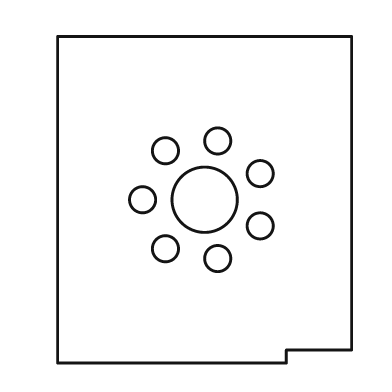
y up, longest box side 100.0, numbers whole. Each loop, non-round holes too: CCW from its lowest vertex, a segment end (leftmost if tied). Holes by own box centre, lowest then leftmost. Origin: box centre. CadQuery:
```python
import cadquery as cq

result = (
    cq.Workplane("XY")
    .moveTo(-45.0, -50.0)
    .lineTo(25.0, -50.0)
    .lineTo(25.0, -46.0)
    .lineTo(45.0, -46.0)
    .lineTo(45.0, 50.0)
    .lineTo(-45.0, 50.0)
    .close()
    .moveTo(4.0, -18.0)
    .circle(4.0)
    .moveTo(-12.0, -15.0)
    .circle(4.0)
    .moveTo(17.0, -8.0)
    .circle(4.0)
    .moveTo(-19.0, 0.0)
    .circle(4.0)
    .moveTo(0.0, 0.0)
    .circle(10.0)
    .moveTo(17.0, 8.0)
    .circle(4.0)
    .moveTo(-12.0, 15.0)
    .circle(4.0)
    .moveTo(4.0, 18.0)
    .circle(4.0)
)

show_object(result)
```